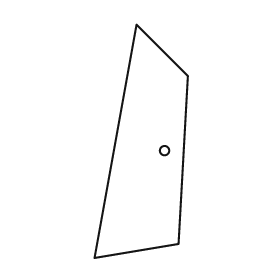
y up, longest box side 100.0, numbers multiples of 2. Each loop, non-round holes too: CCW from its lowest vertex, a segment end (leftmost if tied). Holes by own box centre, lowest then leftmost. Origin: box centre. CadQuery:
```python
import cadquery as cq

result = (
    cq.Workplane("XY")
    .moveTo(-20.0, -50.0)
    .lineTo(16.0, -44.0)
    .lineTo(20.0, 28.0)
    .lineTo(-2.0, 50.0)
    .close()
    .moveTo(10.0, -4.0)
    .circle(2.0)
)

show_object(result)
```